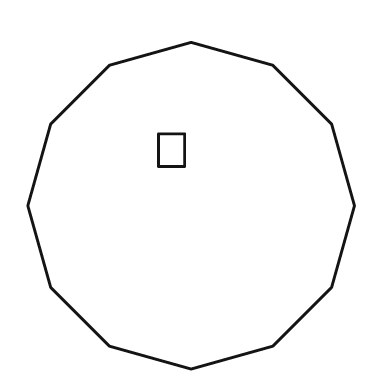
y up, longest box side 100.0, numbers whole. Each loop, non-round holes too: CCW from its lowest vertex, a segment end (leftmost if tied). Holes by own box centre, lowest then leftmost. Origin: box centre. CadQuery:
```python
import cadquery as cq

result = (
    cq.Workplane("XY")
    .moveTo(0.0, -50.0)
    .lineTo(25.0, -43.0)
    .lineTo(43.0, -25.0)
    .lineTo(50.0, 0.0)
    .lineTo(43.0, 25.0)
    .lineTo(25.0, 43.0)
    .lineTo(0.0, 50.0)
    .lineTo(-25.0, 43.0)
    .lineTo(-43.0, 25.0)
    .lineTo(-50.0, 0.0)
    .lineTo(-43.0, -25.0)
    .lineTo(-25.0, -43.0)
    .close()
    .moveTo(-10.0, 12.0)
    .lineTo(-2.0, 12.0)
    .lineTo(-2.0, 22.0)
    .lineTo(-10.0, 22.0)
    .close()
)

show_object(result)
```